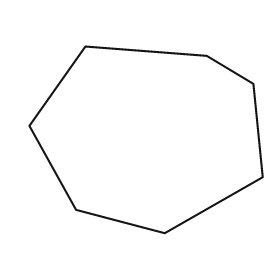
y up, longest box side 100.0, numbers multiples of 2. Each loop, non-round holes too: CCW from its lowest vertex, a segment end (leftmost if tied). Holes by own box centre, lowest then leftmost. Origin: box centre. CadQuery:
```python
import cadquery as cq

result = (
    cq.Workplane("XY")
    .moveTo(8.0, -40.0)
    .lineTo(50.0, -16.0)
    .lineTo(46.0, 24.0)
    .lineTo(26.0, 36.0)
    .lineTo(-26.0, 40.0)
    .lineTo(-50.0, 6.0)
    .lineTo(-30.0, -30.0)
    .close()
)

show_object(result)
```